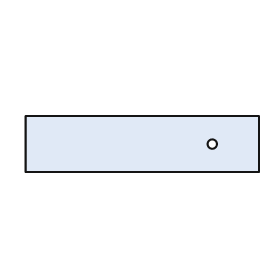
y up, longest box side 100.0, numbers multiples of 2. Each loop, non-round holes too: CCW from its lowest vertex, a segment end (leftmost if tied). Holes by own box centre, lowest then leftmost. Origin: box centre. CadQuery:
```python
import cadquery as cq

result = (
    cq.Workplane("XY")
    .moveTo(-50.0, -12.0)
    .lineTo(50.0, -12.0)
    .lineTo(50.0, 12.0)
    .lineTo(-50.0, 12.0)
    .close()
    .moveTo(30.0, 0.0)
    .circle(2.0)
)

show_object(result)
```